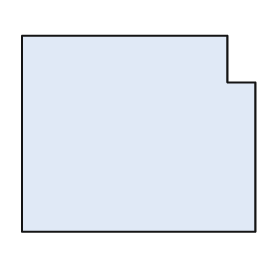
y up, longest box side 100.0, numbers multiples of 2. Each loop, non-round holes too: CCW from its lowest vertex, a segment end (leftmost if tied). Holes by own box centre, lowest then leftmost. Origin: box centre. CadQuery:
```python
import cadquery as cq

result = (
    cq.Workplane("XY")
    .moveTo(-50.0, -42.0)
    .lineTo(50.0, -42.0)
    .lineTo(50.0, 22.0)
    .lineTo(38.0, 22.0)
    .lineTo(38.0, 42.0)
    .lineTo(-50.0, 42.0)
    .close()
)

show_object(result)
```